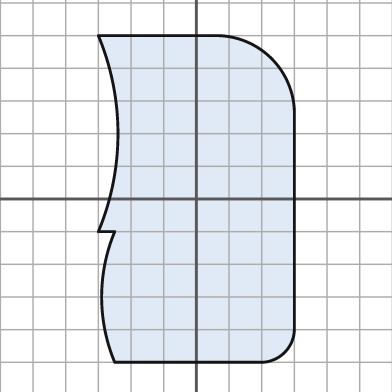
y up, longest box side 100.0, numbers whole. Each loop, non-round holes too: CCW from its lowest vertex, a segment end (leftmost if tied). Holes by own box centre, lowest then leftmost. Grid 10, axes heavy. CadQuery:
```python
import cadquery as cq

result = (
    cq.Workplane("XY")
    .moveTo(-25.0, -50.0)
    .lineTo(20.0, -50.0)
    .threePointArc((27.0, -47.0), (30.0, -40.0))
    .lineTo(30.0, 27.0)
    .threePointArc((23.0, 43.0), (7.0, 50.0))
    .lineTo(-30.0, 50.0)
    .threePointArc((-24.0, 20.0), (-30.0, -10.0))
    .lineTo(-25.0, -10.0)
    .threePointArc((-29.0, -30.0), (-25.0, -50.0))
    .close()
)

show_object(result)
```